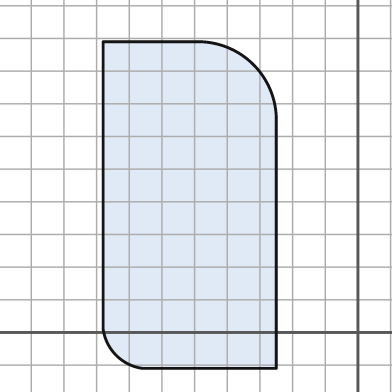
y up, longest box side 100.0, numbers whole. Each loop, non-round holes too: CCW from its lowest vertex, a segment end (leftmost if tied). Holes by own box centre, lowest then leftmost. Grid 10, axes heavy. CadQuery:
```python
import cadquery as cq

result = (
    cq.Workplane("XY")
    .moveTo(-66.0, -11.0)
    .lineTo(-25.0, -11.0)
    .lineTo(-25.0, 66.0)
    .threePointArc((-32.0, 82.0), (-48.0, 89.0))
    .lineTo(-78.0, 89.0)
    .lineTo(-78.0, 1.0)
    .threePointArc((-74.0, -7.0), (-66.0, -11.0))
    .close()
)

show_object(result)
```